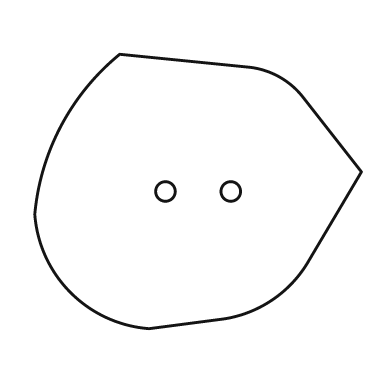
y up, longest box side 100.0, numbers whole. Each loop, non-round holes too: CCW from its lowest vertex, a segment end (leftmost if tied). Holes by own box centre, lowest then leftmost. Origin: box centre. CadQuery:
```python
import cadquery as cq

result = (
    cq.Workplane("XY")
    .moveTo(-15.0, -42.0)
    .lineTo(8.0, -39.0)
    .threePointArc((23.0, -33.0), (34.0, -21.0))
    .lineTo(50.0, 6.0)
    .lineTo(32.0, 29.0)
    .threePointArc((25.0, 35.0), (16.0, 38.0))
    .lineTo(-24.0, 42.0)
    .threePointArc((-42.0, 20.0), (-50.0, -7.0))
    .threePointArc((-39.0, -31.0), (-15.0, -42.0))
    .close()
    .moveTo(-10.0, 0.0)
    .circle(3.0)
    .moveTo(10.0, 0.0)
    .circle(3.0)
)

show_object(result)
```